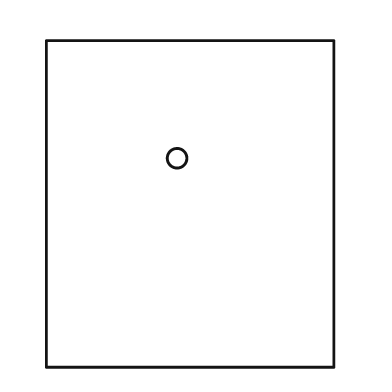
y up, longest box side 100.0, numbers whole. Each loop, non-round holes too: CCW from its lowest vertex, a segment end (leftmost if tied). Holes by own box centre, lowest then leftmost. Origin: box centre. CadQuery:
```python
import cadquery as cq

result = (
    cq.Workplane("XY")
    .moveTo(-44.0, -50.0)
    .lineTo(44.0, -50.0)
    .lineTo(44.0, 50.0)
    .lineTo(-44.0, 50.0)
    .close()
    .moveTo(-4.0, 14.0)
    .circle(3.0)
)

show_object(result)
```